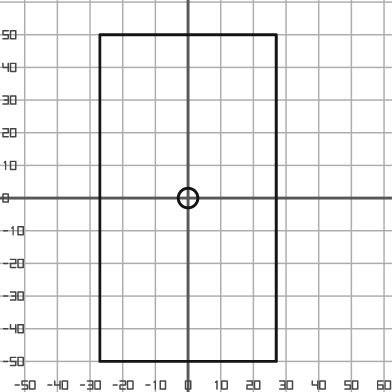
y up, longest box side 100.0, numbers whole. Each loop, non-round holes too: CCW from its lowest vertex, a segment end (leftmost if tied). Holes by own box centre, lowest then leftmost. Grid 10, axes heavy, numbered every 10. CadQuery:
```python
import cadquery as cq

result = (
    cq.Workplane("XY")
    .moveTo(-27.0, -50.0)
    .lineTo(27.0, -50.0)
    .lineTo(27.0, 50.0)
    .lineTo(-27.0, 50.0)
    .close()
    .moveTo(0.0, 0.0)
    .circle(3.0)
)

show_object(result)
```